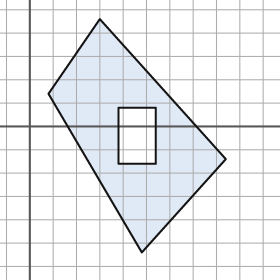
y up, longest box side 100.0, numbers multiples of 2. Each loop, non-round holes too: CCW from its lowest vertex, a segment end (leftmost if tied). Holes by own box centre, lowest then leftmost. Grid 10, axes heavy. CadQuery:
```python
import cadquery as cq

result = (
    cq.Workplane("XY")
    .moveTo(48.0, -54.0)
    .lineTo(84.0, -14.0)
    .lineTo(30.0, 46.0)
    .lineTo(8.0, 14.0)
    .close()
    .moveTo(38.0, -16.0)
    .lineTo(54.0, -16.0)
    .lineTo(54.0, 8.0)
    .lineTo(38.0, 8.0)
    .close()
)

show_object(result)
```